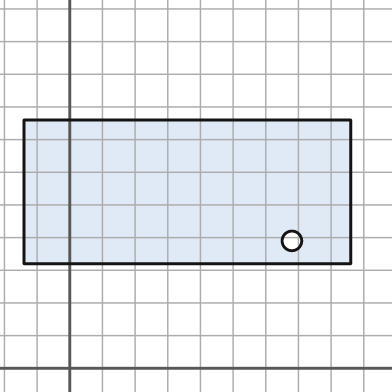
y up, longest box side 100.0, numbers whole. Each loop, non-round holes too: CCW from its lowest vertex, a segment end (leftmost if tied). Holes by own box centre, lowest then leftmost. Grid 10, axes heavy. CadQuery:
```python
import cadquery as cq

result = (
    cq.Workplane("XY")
    .moveTo(-14.0, 32.0)
    .lineTo(86.0, 32.0)
    .lineTo(86.0, 76.0)
    .lineTo(-14.0, 76.0)
    .close()
    .moveTo(68.0, 39.0)
    .circle(3.0)
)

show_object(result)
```